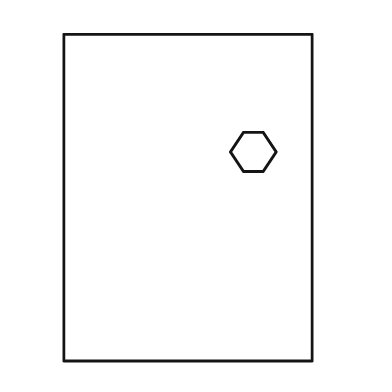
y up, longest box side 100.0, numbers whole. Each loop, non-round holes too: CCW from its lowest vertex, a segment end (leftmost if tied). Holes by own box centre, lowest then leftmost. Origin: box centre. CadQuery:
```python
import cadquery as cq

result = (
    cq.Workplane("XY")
    .moveTo(-38.0, -50.0)
    .lineTo(38.0, -50.0)
    .lineTo(38.0, 50.0)
    .lineTo(-38.0, 50.0)
    .close()
    .moveTo(17.0, 8.0)
    .lineTo(23.0, 8.0)
    .lineTo(27.0, 14.0)
    .lineTo(23.0, 20.0)
    .lineTo(17.0, 20.0)
    .lineTo(13.0, 14.0)
    .close()
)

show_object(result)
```